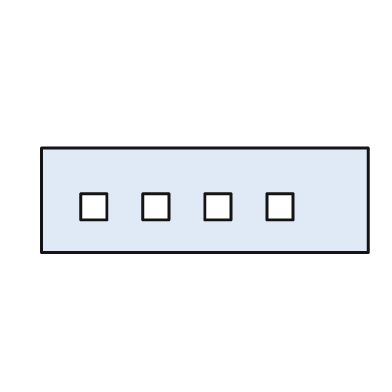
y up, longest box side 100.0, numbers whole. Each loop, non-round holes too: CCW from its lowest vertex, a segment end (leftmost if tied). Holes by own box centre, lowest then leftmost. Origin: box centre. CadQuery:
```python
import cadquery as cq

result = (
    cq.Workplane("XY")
    .moveTo(-50.0, -16.0)
    .lineTo(50.0, -16.0)
    .lineTo(50.0, 16.0)
    .lineTo(-50.0, 16.0)
    .close()
    .moveTo(-38.0, -6.0)
    .lineTo(-30.0, -6.0)
    .lineTo(-30.0, 2.0)
    .lineTo(-38.0, 2.0)
    .close()
    .moveTo(-19.0, -6.0)
    .lineTo(-11.0, -6.0)
    .lineTo(-11.0, 2.0)
    .lineTo(-19.0, 2.0)
    .close()
    .moveTo(0.0, -6.0)
    .lineTo(8.0, -6.0)
    .lineTo(8.0, 2.0)
    .lineTo(0.0, 2.0)
    .close()
    .moveTo(19.0, -6.0)
    .lineTo(27.0, -6.0)
    .lineTo(27.0, 2.0)
    .lineTo(19.0, 2.0)
    .close()
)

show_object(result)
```